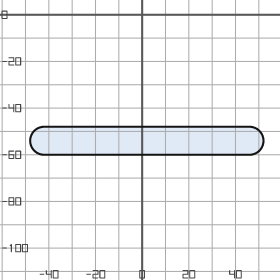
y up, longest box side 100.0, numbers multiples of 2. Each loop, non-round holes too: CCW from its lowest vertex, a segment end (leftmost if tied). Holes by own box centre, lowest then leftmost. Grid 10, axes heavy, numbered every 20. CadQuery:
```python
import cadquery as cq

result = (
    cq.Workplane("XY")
    .moveTo(-42.0, -60.0)
    .lineTo(46.0, -60.0)
    .threePointArc((52.0, -54.0), (46.0, -48.0))
    .lineTo(-42.0, -48.0)
    .threePointArc((-48.0, -54.0), (-42.0, -60.0))
    .close()
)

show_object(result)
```